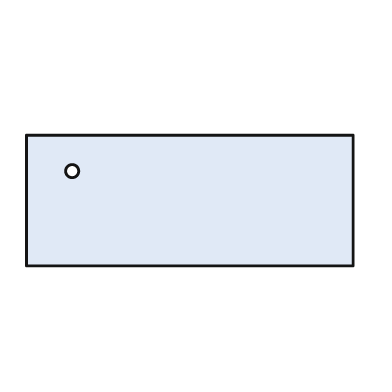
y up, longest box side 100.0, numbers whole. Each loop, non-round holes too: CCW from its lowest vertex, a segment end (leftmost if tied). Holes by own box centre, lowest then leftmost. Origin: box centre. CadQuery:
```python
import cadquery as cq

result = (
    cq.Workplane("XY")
    .moveTo(-50.0, -20.0)
    .lineTo(50.0, -20.0)
    .lineTo(50.0, 20.0)
    .lineTo(-50.0, 20.0)
    .close()
    .moveTo(-36.0, 9.0)
    .circle(2.0)
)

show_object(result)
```